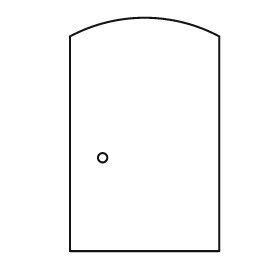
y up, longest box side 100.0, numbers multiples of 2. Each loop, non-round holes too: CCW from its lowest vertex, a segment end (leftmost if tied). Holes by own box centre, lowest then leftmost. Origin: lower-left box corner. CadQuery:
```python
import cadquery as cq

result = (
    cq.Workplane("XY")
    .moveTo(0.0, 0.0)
    .lineTo(64.0, 0.0)
    .lineTo(64.0, 92.0)
    .threePointArc((32.0, 100.0), (0.0, 92.0))
    .close()
    .moveTo(14.0, 40.0)
    .circle(2.0)
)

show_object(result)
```